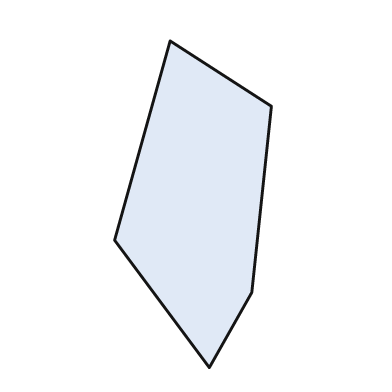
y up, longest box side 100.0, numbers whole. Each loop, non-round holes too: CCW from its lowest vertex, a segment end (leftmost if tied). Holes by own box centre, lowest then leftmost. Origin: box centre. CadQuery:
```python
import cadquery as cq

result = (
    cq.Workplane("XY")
    .moveTo(5.0, -50.0)
    .lineTo(18.0, -27.0)
    .lineTo(24.0, 30.0)
    .lineTo(-7.0, 50.0)
    .lineTo(-24.0, -11.0)
    .close()
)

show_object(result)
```